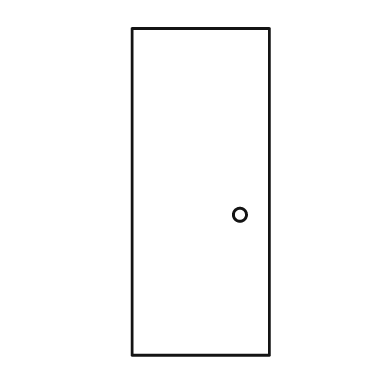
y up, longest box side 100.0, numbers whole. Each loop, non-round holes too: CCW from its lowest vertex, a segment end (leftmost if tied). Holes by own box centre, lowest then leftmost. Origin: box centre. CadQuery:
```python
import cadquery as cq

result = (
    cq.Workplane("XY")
    .moveTo(-21.0, -50.0)
    .lineTo(21.0, -50.0)
    .lineTo(21.0, 50.0)
    .lineTo(-21.0, 50.0)
    .close()
    .moveTo(12.0, -7.0)
    .circle(2.0)
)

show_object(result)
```